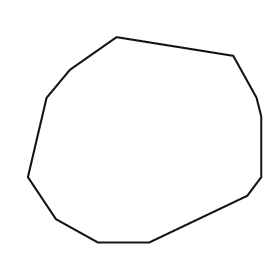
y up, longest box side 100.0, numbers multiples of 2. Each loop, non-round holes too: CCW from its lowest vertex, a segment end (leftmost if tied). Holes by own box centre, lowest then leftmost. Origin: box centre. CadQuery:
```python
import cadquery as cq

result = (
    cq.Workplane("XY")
    .moveTo(-20.0, -44.0)
    .lineTo(2.0, -44.0)
    .lineTo(44.0, -24.0)
    .lineTo(50.0, -16.0)
    .lineTo(50.0, 10.0)
    .lineTo(48.0, 18.0)
    .lineTo(38.0, 36.0)
    .lineTo(-12.0, 44.0)
    .lineTo(-32.0, 30.0)
    .lineTo(-42.0, 18.0)
    .lineTo(-50.0, -16.0)
    .lineTo(-38.0, -34.0)
    .close()
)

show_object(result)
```